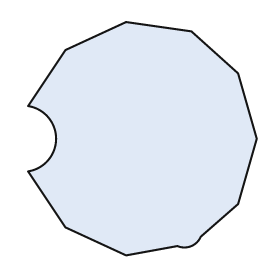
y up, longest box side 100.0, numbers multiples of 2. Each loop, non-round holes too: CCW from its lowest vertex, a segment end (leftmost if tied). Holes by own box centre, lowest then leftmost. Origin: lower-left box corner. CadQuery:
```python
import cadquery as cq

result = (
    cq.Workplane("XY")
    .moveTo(42.0, 0.0)
    .lineTo(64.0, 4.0)
    .threePointArc((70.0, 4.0), (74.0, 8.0))
    .lineTo(90.0, 22.0)
    .lineTo(98.0, 50.0)
    .lineTo(90.0, 78.0)
    .lineTo(70.0, 96.0)
    .lineTo(42.0, 100.0)
    .lineTo(16.0, 88.0)
    .lineTo(0.0, 64.0)
    .threePointArc((12.0, 50.0), (0.0, 36.0))
    .lineTo(16.0, 12.0)
    .close()
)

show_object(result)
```